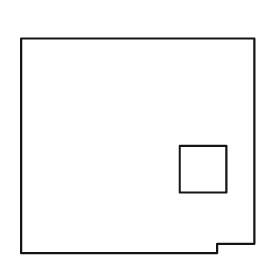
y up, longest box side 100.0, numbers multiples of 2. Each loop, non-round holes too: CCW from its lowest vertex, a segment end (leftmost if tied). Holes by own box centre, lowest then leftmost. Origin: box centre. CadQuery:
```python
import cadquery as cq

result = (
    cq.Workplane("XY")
    .moveTo(-50.0, -46.0)
    .lineTo(34.0, -46.0)
    .lineTo(34.0, -42.0)
    .lineTo(50.0, -42.0)
    .lineTo(50.0, 46.0)
    .lineTo(-50.0, 46.0)
    .close()
    .moveTo(18.0, -20.0)
    .lineTo(38.0, -20.0)
    .lineTo(38.0, 0.0)
    .lineTo(18.0, 0.0)
    .close()
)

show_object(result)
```